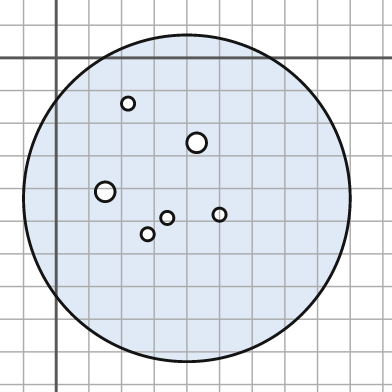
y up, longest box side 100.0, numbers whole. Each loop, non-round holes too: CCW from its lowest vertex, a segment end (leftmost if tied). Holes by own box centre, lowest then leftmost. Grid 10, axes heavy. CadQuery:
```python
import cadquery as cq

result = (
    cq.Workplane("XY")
    .moveTo(40.0, -43.0)
    .circle(50.0)
    .moveTo(28.0, -54.0)
    .circle(2.0)
    .moveTo(34.0, -49.0)
    .circle(2.0)
    .moveTo(50.0, -48.0)
    .circle(2.0)
    .moveTo(15.0, -41.0)
    .circle(3.0)
    .moveTo(43.0, -26.0)
    .circle(3.0)
    .moveTo(22.0, -14.0)
    .circle(2.0)
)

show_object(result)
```